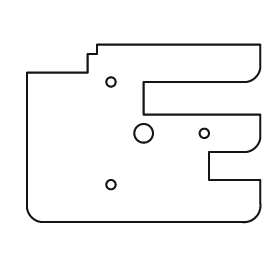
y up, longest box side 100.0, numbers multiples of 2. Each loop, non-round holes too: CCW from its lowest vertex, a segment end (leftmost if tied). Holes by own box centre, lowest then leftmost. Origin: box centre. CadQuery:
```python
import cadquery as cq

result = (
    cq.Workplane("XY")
    .moveTo(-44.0, -38.0)
    .lineTo(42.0, -38.0)
    .threePointArc((48.0, -36.0), (50.0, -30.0))
    .lineTo(50.0, -20.0)
    .lineTo(28.0, -20.0)
    .lineTo(28.0, -8.0)
    .lineTo(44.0, -8.0)
    .threePointArc((48.0, -6.0), (50.0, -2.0))
    .lineTo(50.0, 8.0)
    .lineTo(0.0, 8.0)
    .lineTo(0.0, 22.0)
    .lineTo(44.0, 22.0)
    .threePointArc((48.0, 24.0), (50.0, 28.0))
    .lineTo(50.0, 38.0)
    .lineTo(-20.0, 38.0)
    .lineTo(-20.0, 34.0)
    .lineTo(-24.0, 34.0)
    .lineTo(-24.0, 26.0)
    .lineTo(-50.0, 26.0)
    .lineTo(-50.0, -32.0)
    .threePointArc((-48.0, -36.0), (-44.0, -38.0))
    .close()
    .moveTo(-14.0, -22.0)
    .circle(2.0)
    .moveTo(0.0, 0.0)
    .circle(4.0)
    .moveTo(26.0, 0.0)
    .circle(2.0)
    .moveTo(-14.0, 22.0)
    .circle(2.0)
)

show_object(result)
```